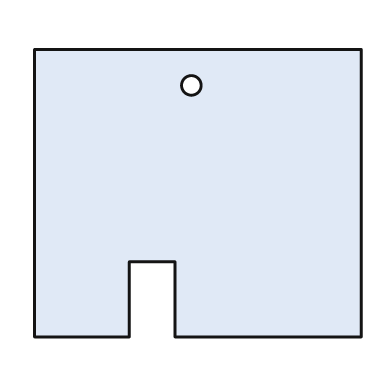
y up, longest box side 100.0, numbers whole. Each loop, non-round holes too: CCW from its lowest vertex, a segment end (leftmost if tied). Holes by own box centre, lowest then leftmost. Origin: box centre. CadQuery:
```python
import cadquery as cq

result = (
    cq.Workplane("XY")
    .moveTo(-50.0, -44.0)
    .lineTo(-21.0, -44.0)
    .lineTo(-21.0, -21.0)
    .lineTo(-7.0, -21.0)
    .lineTo(-7.0, -44.0)
    .lineTo(50.0, -44.0)
    .lineTo(50.0, 44.0)
    .lineTo(-50.0, 44.0)
    .close()
    .moveTo(-2.0, 33.0)
    .circle(3.0)
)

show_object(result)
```